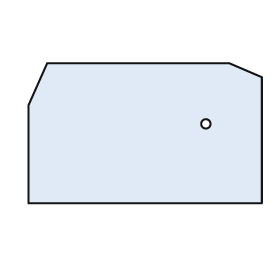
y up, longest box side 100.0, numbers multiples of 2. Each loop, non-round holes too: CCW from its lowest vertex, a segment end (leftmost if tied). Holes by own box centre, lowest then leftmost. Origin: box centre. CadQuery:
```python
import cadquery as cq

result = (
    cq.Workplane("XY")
    .moveTo(-50.0, -30.0)
    .lineTo(50.0, -30.0)
    .lineTo(50.0, 24.0)
    .lineTo(36.0, 30.0)
    .lineTo(-42.0, 30.0)
    .lineTo(-50.0, 12.0)
    .close()
    .moveTo(26.0, 4.0)
    .circle(2.0)
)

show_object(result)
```